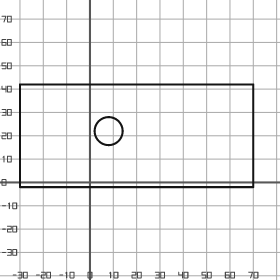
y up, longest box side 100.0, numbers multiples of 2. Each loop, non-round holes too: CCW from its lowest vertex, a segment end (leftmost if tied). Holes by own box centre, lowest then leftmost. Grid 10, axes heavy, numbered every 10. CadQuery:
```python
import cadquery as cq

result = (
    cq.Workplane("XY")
    .moveTo(-30.0, -2.0)
    .lineTo(70.0, -2.0)
    .lineTo(70.0, 42.0)
    .lineTo(-30.0, 42.0)
    .close()
    .moveTo(8.0, 22.0)
    .circle(6.0)
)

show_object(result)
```